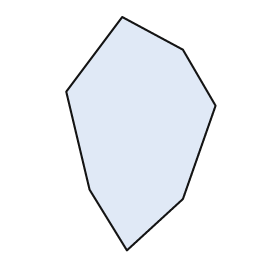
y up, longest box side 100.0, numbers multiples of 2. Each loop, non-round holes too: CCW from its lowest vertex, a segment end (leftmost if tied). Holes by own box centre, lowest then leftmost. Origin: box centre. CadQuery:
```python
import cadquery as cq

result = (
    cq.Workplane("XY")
    .moveTo(-6.0, -50.0)
    .lineTo(18.0, -28.0)
    .lineTo(32.0, 12.0)
    .lineTo(18.0, 36.0)
    .lineTo(-8.0, 50.0)
    .lineTo(-32.0, 18.0)
    .lineTo(-22.0, -24.0)
    .close()
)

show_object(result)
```